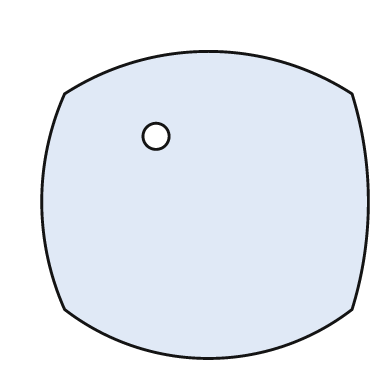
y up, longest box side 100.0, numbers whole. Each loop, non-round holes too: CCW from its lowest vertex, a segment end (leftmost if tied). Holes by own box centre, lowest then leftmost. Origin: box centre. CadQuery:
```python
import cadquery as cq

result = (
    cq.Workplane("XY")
    .moveTo(-43.0, -32.0)
    .threePointArc((1.0, -47.0), (45.0, -32.0))
    .threePointArc((50.0, 1.0), (45.0, 34.0))
    .threePointArc((1.0, 47.0), (-43.0, 34.0))
    .threePointArc((-50.0, 1.0), (-43.0, -32.0))
    .close()
    .moveTo(-15.0, 21.0)
    .circle(4.0)
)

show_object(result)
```